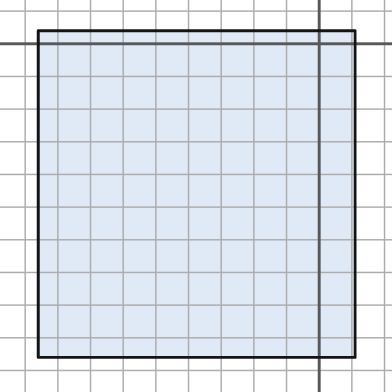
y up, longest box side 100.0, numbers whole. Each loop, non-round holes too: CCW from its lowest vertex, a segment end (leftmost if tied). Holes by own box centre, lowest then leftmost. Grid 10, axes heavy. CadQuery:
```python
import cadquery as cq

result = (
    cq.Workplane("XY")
    .moveTo(-86.0, -96.0)
    .lineTo(11.0, -96.0)
    .lineTo(11.0, 4.0)
    .lineTo(-86.0, 4.0)
    .close()
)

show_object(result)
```